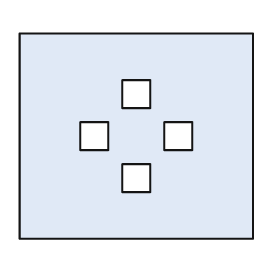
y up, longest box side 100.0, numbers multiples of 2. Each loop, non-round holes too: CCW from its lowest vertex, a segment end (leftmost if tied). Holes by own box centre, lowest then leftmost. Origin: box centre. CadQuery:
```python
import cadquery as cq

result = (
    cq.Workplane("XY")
    .moveTo(-50.0, -44.0)
    .lineTo(50.0, -44.0)
    .lineTo(50.0, 44.0)
    .lineTo(-50.0, 44.0)
    .close()
    .moveTo(-6.0, -24.0)
    .lineTo(6.0, -24.0)
    .lineTo(6.0, -12.0)
    .lineTo(-6.0, -12.0)
    .close()
    .moveTo(-24.0, -6.0)
    .lineTo(-12.0, -6.0)
    .lineTo(-12.0, 6.0)
    .lineTo(-24.0, 6.0)
    .close()
    .moveTo(12.0, -6.0)
    .lineTo(24.0, -6.0)
    .lineTo(24.0, 6.0)
    .lineTo(12.0, 6.0)
    .close()
    .moveTo(-6.0, 12.0)
    .lineTo(6.0, 12.0)
    .lineTo(6.0, 24.0)
    .lineTo(-6.0, 24.0)
    .close()
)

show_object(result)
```